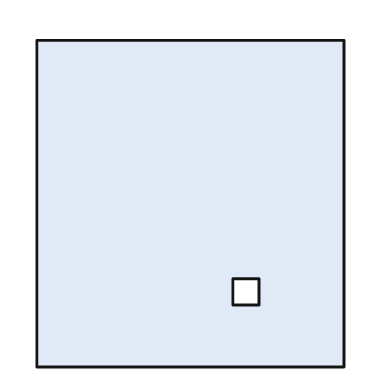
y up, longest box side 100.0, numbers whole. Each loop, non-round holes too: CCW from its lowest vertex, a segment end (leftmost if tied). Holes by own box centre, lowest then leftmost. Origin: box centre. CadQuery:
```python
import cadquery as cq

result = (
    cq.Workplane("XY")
    .moveTo(-47.0, -50.0)
    .lineTo(47.0, -50.0)
    .lineTo(47.0, 50.0)
    .lineTo(-47.0, 50.0)
    .close()
    .moveTo(13.0, -31.0)
    .lineTo(21.0, -31.0)
    .lineTo(21.0, -23.0)
    .lineTo(13.0, -23.0)
    .close()
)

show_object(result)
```